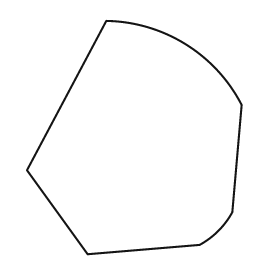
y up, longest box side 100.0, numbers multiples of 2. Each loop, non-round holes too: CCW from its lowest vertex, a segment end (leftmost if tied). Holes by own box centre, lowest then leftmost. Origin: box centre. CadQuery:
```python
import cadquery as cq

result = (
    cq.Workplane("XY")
    .moveTo(-20.0, -50.0)
    .lineTo(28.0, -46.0)
    .threePointArc((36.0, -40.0), (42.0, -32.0))
    .lineTo(46.0, 14.0)
    .threePointArc((22.0, 40.0), (-12.0, 50.0))
    .lineTo(-46.0, -14.0)
    .close()
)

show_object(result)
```